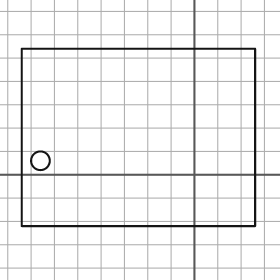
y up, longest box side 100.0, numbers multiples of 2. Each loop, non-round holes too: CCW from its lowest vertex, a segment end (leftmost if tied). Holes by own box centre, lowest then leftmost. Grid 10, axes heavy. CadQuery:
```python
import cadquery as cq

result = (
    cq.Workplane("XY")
    .moveTo(-74.0, -22.0)
    .lineTo(26.0, -22.0)
    .lineTo(26.0, 54.0)
    .lineTo(-74.0, 54.0)
    .close()
    .moveTo(-66.0, 6.0)
    .circle(4.0)
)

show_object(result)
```